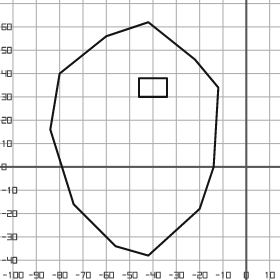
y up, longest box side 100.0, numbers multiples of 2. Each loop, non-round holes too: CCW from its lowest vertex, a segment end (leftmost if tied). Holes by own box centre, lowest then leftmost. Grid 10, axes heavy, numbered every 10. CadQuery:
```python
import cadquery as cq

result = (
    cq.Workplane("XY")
    .moveTo(-42.0, -38.0)
    .lineTo(-20.0, -18.0)
    .lineTo(-14.0, 0.0)
    .lineTo(-12.0, 34.0)
    .lineTo(-22.0, 46.0)
    .lineTo(-42.0, 62.0)
    .lineTo(-60.0, 56.0)
    .lineTo(-80.0, 40.0)
    .lineTo(-84.0, 16.0)
    .lineTo(-74.0, -16.0)
    .lineTo(-56.0, -34.0)
    .close()
    .moveTo(-46.0, 30.0)
    .lineTo(-34.0, 30.0)
    .lineTo(-34.0, 38.0)
    .lineTo(-46.0, 38.0)
    .close()
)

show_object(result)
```